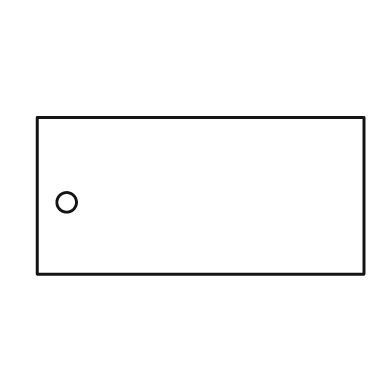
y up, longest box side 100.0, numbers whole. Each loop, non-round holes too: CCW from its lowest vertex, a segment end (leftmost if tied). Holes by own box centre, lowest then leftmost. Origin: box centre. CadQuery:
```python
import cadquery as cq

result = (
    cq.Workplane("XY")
    .moveTo(-50.0, -24.0)
    .lineTo(50.0, -24.0)
    .lineTo(50.0, 24.0)
    .lineTo(-50.0, 24.0)
    .close()
    .moveTo(-41.0, -2.0)
    .circle(3.0)
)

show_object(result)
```